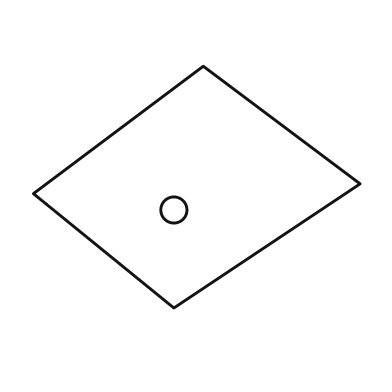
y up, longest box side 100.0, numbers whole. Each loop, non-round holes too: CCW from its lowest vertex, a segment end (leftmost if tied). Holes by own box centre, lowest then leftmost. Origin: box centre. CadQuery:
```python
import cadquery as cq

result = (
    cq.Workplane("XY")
    .moveTo(-7.0, -37.0)
    .lineTo(50.0, 1.0)
    .lineTo(2.0, 37.0)
    .lineTo(-50.0, -2.0)
    .close()
    .moveTo(-7.0, -7.0)
    .circle(4.0)
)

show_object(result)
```